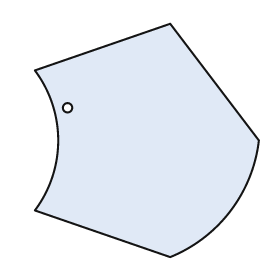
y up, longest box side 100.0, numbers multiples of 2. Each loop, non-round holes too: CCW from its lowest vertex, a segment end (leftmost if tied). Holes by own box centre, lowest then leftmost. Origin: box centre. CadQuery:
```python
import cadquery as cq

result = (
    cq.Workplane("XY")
    .moveTo(10.0, -50.0)
    .threePointArc((36.0, -30.0), (48.0, 0.0))
    .lineTo(10.0, 50.0)
    .lineTo(-48.0, 30.0)
    .threePointArc((-38.0, 0.0), (-48.0, -30.0))
    .close()
    .moveTo(-34.0, 14.0)
    .circle(2.0)
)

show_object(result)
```